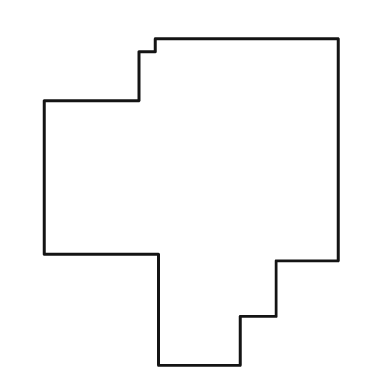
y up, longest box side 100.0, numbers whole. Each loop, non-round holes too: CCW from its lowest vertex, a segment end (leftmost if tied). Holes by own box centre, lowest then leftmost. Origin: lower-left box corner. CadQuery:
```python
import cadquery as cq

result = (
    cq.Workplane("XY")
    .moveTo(35.0, 0.0)
    .lineTo(60.0, 0.0)
    .lineTo(60.0, 15.0)
    .lineTo(71.0, 15.0)
    .lineTo(71.0, 32.0)
    .lineTo(90.0, 32.0)
    .lineTo(90.0, 100.0)
    .lineTo(34.0, 100.0)
    .lineTo(34.0, 96.0)
    .lineTo(29.0, 96.0)
    .lineTo(29.0, 81.0)
    .lineTo(0.0, 81.0)
    .lineTo(0.0, 34.0)
    .lineTo(35.0, 34.0)
    .close()
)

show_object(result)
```